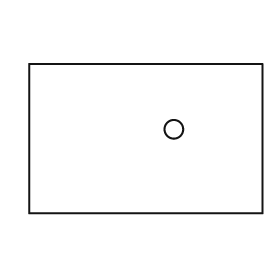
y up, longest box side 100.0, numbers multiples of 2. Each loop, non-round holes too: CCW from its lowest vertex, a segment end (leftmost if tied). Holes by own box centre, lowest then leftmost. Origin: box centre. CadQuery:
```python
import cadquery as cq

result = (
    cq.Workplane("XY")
    .moveTo(-50.0, -32.0)
    .lineTo(50.0, -32.0)
    .lineTo(50.0, 32.0)
    .lineTo(-50.0, 32.0)
    .close()
    .moveTo(12.0, 4.0)
    .circle(4.0)
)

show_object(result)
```